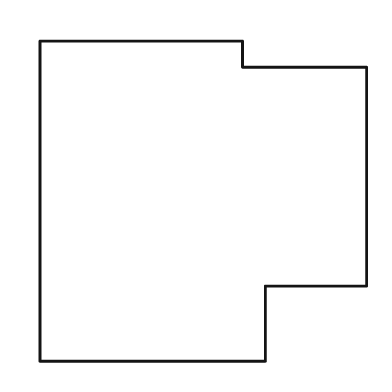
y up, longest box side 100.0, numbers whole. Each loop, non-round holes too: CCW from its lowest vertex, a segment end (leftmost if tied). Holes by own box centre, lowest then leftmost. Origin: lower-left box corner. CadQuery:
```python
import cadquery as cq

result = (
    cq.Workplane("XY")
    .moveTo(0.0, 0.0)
    .lineTo(69.0, 0.0)
    .lineTo(69.0, 23.0)
    .lineTo(100.0, 23.0)
    .lineTo(100.0, 90.0)
    .lineTo(62.0, 90.0)
    .lineTo(62.0, 98.0)
    .lineTo(0.0, 98.0)
    .close()
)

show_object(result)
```